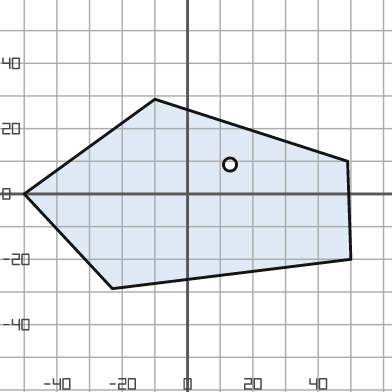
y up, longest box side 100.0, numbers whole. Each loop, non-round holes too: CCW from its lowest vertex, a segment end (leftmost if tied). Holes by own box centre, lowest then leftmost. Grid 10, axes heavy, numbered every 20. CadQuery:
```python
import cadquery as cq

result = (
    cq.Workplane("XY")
    .moveTo(-23.0, -29.0)
    .lineTo(50.0, -20.0)
    .lineTo(49.0, 10.0)
    .lineTo(-10.0, 29.0)
    .lineTo(-50.0, 0.0)
    .close()
    .moveTo(13.0, 9.0)
    .circle(2.0)
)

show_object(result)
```